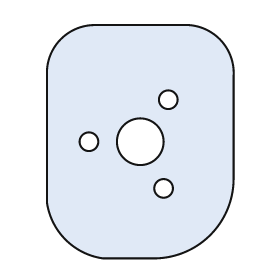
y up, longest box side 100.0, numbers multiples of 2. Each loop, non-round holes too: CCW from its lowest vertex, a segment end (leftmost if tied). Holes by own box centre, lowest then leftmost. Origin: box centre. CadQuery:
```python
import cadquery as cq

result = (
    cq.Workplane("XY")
    .moveTo(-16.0, -50.0)
    .lineTo(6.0, -50.0)
    .threePointArc((30.0, -40.0), (40.0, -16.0))
    .lineTo(40.0, 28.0)
    .threePointArc((34.0, 44.0), (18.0, 50.0))
    .lineTo(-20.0, 50.0)
    .threePointArc((-34.0, 44.0), (-40.0, 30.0))
    .lineTo(-40.0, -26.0)
    .threePointArc((-32.0, -42.0), (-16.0, -50.0))
    .close()
    .moveTo(10.0, -20.0)
    .circle(4.0)
    .moveTo(-22.0, 0.0)
    .circle(4.0)
    .moveTo(0.0, 0.0)
    .circle(10.0)
    .moveTo(12.0, 18.0)
    .circle(4.0)
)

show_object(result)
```